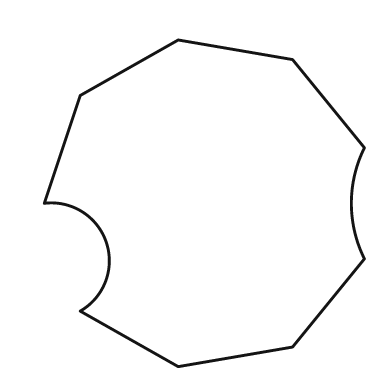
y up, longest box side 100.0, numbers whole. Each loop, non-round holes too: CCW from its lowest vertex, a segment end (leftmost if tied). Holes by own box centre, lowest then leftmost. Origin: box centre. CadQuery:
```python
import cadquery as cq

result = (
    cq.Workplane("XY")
    .moveTo(-8.0, -50.0)
    .lineTo(27.0, -44.0)
    .lineTo(49.0, -17.0)
    .threePointArc((45.0, 0.0), (49.0, 17.0))
    .lineTo(27.0, 44.0)
    .lineTo(-8.0, 50.0)
    .lineTo(-38.0, 33.0)
    .lineTo(-49.0, 0.0)
    .threePointArc((-30.0, -12.0), (-38.0, -33.0))
    .close()
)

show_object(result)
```